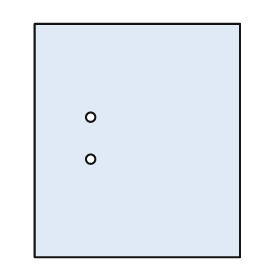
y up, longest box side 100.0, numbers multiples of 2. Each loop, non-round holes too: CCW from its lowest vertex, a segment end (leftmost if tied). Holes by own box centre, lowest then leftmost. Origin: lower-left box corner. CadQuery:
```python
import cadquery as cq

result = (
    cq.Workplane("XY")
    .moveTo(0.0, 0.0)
    .lineTo(88.0, 0.0)
    .lineTo(88.0, 100.0)
    .lineTo(0.0, 100.0)
    .close()
    .moveTo(24.0, 42.0)
    .circle(2.0)
    .moveTo(24.0, 60.0)
    .circle(2.0)
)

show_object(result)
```